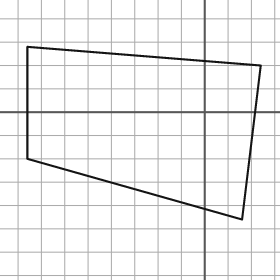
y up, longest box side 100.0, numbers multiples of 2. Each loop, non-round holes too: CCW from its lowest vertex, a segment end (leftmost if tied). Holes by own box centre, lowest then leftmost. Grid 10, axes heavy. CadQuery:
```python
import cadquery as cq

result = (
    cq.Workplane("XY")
    .moveTo(16.0, -46.0)
    .lineTo(24.0, 20.0)
    .lineTo(-76.0, 28.0)
    .lineTo(-76.0, -20.0)
    .close()
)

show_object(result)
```